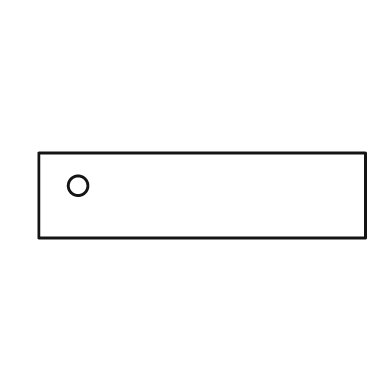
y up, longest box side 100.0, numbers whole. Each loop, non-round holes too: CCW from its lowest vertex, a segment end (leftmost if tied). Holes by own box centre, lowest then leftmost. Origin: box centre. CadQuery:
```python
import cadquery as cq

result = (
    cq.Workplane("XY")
    .moveTo(-50.0, -13.0)
    .lineTo(50.0, -13.0)
    .lineTo(50.0, 13.0)
    .lineTo(-50.0, 13.0)
    .close()
    .moveTo(-38.0, 3.0)
    .circle(3.0)
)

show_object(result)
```